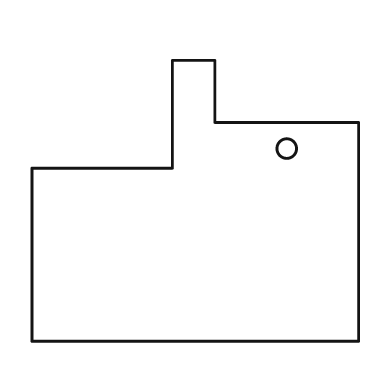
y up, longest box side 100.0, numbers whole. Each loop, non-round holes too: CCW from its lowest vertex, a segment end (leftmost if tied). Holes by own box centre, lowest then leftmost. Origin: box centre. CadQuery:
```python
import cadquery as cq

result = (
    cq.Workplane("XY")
    .moveTo(-50.0, -43.0)
    .lineTo(50.0, -43.0)
    .lineTo(50.0, 24.0)
    .lineTo(6.0, 24.0)
    .lineTo(6.0, 43.0)
    .lineTo(-7.0, 43.0)
    .lineTo(-7.0, 10.0)
    .lineTo(-50.0, 10.0)
    .close()
    .moveTo(28.0, 16.0)
    .circle(3.0)
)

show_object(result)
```